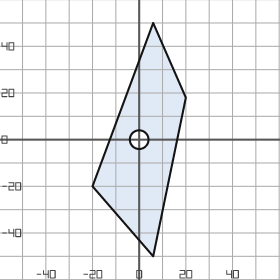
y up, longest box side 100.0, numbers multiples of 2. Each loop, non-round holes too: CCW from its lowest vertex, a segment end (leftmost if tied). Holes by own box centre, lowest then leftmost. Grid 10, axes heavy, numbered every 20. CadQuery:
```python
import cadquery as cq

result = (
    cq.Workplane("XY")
    .moveTo(6.0, -50.0)
    .lineTo(20.0, 18.0)
    .lineTo(6.0, 50.0)
    .lineTo(-20.0, -20.0)
    .close()
    .moveTo(0.0, 0.0)
    .circle(4.0)
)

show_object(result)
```